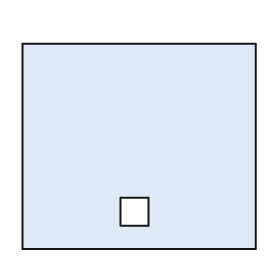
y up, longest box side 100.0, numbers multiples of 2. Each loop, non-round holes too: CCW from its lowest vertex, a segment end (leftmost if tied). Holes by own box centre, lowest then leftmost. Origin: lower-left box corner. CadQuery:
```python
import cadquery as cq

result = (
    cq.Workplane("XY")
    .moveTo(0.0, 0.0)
    .lineTo(100.0, 0.0)
    .lineTo(100.0, 88.0)
    .lineTo(0.0, 88.0)
    .close()
    .moveTo(42.0, 10.0)
    .lineTo(54.0, 10.0)
    .lineTo(54.0, 22.0)
    .lineTo(42.0, 22.0)
    .close()
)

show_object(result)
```